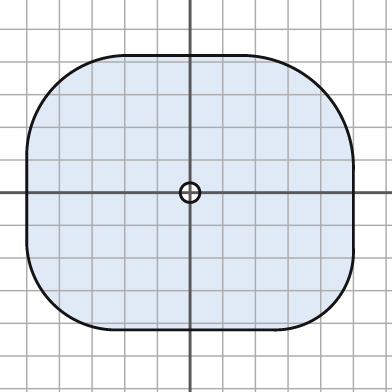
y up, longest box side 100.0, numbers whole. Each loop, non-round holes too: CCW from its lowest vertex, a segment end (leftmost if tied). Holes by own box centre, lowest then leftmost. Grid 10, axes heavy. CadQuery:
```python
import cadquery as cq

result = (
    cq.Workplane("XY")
    .moveTo(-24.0, -42.0)
    .lineTo(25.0, -42.0)
    .threePointArc((43.0, -35.0), (50.0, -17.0))
    .lineTo(50.0, 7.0)
    .threePointArc((40.0, 32.0), (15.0, 42.0))
    .lineTo(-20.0, 42.0)
    .threePointArc((-41.0, 33.0), (-50.0, 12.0))
    .lineTo(-50.0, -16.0)
    .threePointArc((-42.0, -34.0), (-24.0, -42.0))
    .close()
    .moveTo(0.0, 0.0)
    .circle(3.0)
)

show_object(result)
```